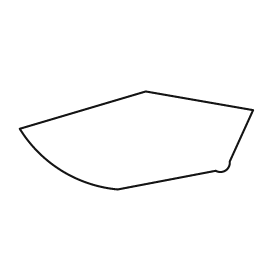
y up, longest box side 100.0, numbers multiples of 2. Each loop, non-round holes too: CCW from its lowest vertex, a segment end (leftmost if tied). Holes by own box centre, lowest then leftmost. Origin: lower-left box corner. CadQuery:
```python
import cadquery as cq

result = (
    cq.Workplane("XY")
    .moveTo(42.0, 0.0)
    .lineTo(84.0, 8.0)
    .threePointArc((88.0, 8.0), (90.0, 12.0))
    .lineTo(100.0, 34.0)
    .lineTo(54.0, 42.0)
    .lineTo(0.0, 26.0)
    .threePointArc((18.0, 8.0), (42.0, 0.0))
    .close()
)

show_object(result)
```